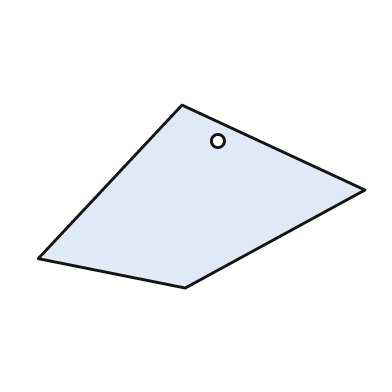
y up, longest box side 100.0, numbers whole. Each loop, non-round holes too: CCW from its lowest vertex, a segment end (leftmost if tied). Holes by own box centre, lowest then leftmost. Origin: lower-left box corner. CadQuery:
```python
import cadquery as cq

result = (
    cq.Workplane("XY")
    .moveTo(45.0, 0.0)
    .lineTo(100.0, 30.0)
    .lineTo(44.0, 56.0)
    .lineTo(0.0, 9.0)
    .close()
    .moveTo(55.0, 45.0)
    .circle(2.0)
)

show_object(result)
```